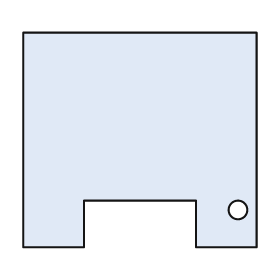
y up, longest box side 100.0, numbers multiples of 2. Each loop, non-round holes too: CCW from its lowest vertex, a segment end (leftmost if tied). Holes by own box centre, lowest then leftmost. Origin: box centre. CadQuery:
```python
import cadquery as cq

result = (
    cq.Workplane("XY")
    .moveTo(-50.0, -46.0)
    .lineTo(-24.0, -46.0)
    .lineTo(-24.0, -26.0)
    .lineTo(24.0, -26.0)
    .lineTo(24.0, -46.0)
    .lineTo(50.0, -46.0)
    .lineTo(50.0, 46.0)
    .lineTo(-50.0, 46.0)
    .close()
    .moveTo(42.0, -30.0)
    .circle(4.0)
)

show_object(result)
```